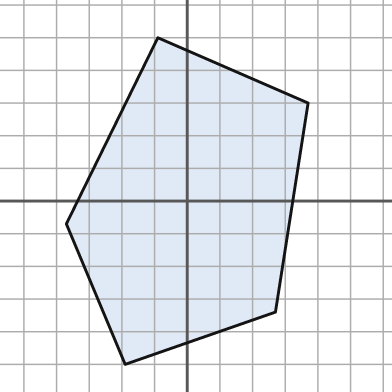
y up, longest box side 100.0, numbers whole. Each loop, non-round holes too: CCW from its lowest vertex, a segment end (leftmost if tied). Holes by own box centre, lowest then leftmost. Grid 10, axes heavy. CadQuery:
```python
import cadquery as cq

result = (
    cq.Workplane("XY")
    .moveTo(-19.0, -50.0)
    .lineTo(27.0, -34.0)
    .lineTo(37.0, 30.0)
    .lineTo(-9.0, 50.0)
    .lineTo(-37.0, -7.0)
    .close()
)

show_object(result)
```